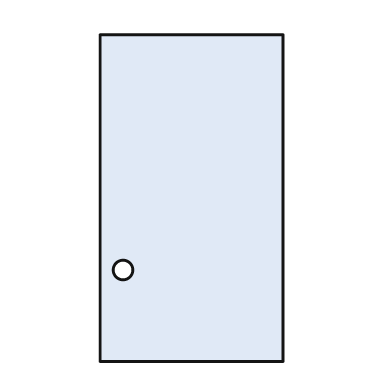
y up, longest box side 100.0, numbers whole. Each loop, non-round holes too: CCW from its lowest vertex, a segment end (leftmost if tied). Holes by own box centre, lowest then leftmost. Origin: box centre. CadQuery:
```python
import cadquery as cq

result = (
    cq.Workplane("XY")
    .moveTo(-28.0, -50.0)
    .lineTo(28.0, -50.0)
    .lineTo(28.0, 50.0)
    .lineTo(-28.0, 50.0)
    .close()
    .moveTo(-21.0, -22.0)
    .circle(3.0)
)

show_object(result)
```